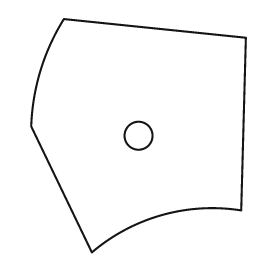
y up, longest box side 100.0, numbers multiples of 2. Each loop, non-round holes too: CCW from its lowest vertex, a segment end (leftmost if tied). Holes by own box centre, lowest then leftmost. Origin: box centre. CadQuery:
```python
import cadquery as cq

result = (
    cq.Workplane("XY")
    .moveTo(-20.0, -50.0)
    .threePointArc((10.0, -34.0), (44.0, -32.0))
    .lineTo(46.0, 42.0)
    .lineTo(-32.0, 50.0)
    .threePointArc((-42.0, 28.0), (-46.0, 4.0))
    .close()
    .moveTo(0.0, 0.0)
    .circle(6.0)
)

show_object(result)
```